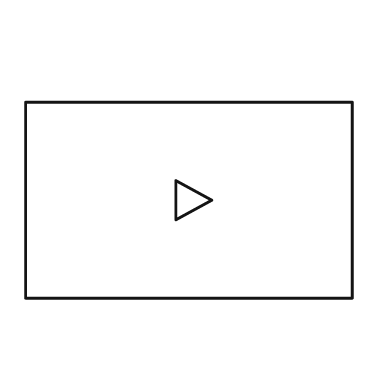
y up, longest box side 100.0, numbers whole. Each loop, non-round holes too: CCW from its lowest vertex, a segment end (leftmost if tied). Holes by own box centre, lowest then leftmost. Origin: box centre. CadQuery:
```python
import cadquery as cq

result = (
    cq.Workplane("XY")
    .moveTo(-50.0, -30.0)
    .lineTo(50.0, -30.0)
    .lineTo(50.0, 30.0)
    .lineTo(-50.0, 30.0)
    .close()
    .moveTo(-4.0, -6.0)
    .lineTo(7.0, 0.0)
    .lineTo(-4.0, 6.0)
    .close()
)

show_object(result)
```